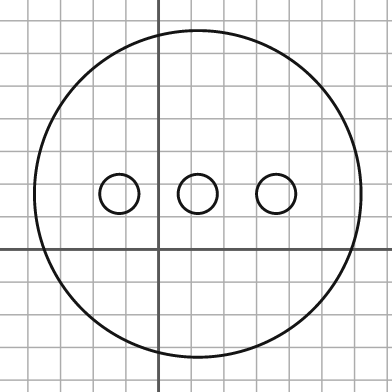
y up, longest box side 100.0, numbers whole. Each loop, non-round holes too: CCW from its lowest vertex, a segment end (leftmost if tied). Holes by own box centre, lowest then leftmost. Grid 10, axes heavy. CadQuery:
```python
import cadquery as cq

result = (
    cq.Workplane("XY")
    .moveTo(12.0, 17.0)
    .circle(50.0)
    .moveTo(-12.0, 17.0)
    .circle(6.0)
    .moveTo(12.0, 17.0)
    .circle(6.0)
    .moveTo(36.0, 17.0)
    .circle(6.0)
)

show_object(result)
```